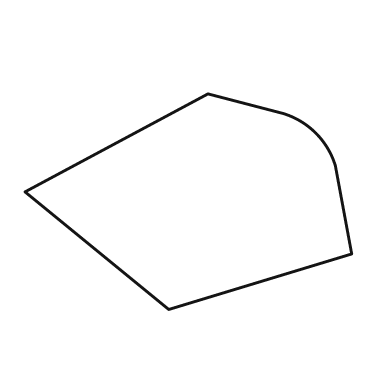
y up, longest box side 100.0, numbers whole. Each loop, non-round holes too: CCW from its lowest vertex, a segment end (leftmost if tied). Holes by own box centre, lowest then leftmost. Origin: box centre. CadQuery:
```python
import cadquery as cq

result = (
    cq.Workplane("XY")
    .moveTo(-6.0, -33.0)
    .lineTo(50.0, -16.0)
    .lineTo(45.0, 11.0)
    .threePointArc((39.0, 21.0), (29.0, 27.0))
    .lineTo(6.0, 33.0)
    .lineTo(-50.0, 3.0)
    .close()
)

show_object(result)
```